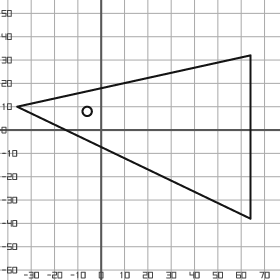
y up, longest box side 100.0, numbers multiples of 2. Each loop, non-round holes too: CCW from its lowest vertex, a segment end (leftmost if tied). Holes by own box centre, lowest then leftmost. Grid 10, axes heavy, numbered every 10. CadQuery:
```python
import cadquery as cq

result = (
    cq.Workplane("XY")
    .moveTo(64.0, -38.0)
    .lineTo(64.0, 32.0)
    .lineTo(-36.0, 10.0)
    .close()
    .moveTo(-6.0, 8.0)
    .circle(2.0)
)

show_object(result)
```